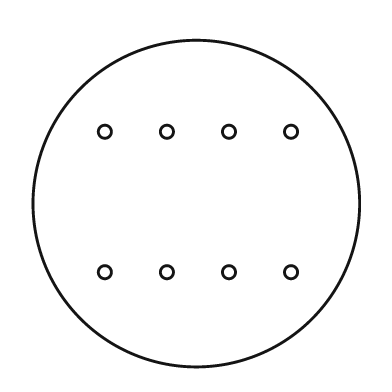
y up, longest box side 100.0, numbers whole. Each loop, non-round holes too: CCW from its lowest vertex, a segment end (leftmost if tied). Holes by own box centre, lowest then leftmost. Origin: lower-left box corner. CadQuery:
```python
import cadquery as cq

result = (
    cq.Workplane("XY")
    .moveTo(50.0, 50.0)
    .circle(50.0)
    .moveTo(22.0, 29.0)
    .circle(2.0)
    .moveTo(41.0, 29.0)
    .circle(2.0)
    .moveTo(60.0, 29.0)
    .circle(2.0)
    .moveTo(79.0, 29.0)
    .circle(2.0)
    .moveTo(22.0, 72.0)
    .circle(2.0)
    .moveTo(41.0, 72.0)
    .circle(2.0)
    .moveTo(60.0, 72.0)
    .circle(2.0)
    .moveTo(79.0, 72.0)
    .circle(2.0)
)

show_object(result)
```